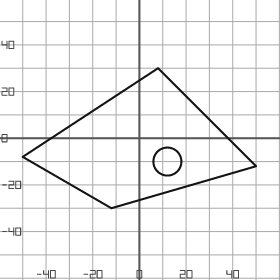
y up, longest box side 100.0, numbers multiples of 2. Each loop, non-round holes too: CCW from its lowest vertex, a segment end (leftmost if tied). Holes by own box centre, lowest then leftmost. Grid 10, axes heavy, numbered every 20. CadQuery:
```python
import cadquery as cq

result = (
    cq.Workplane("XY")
    .moveTo(-12.0, -30.0)
    .lineTo(50.0, -12.0)
    .lineTo(8.0, 30.0)
    .lineTo(-50.0, -8.0)
    .close()
    .moveTo(12.0, -10.0)
    .circle(6.0)
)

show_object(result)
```